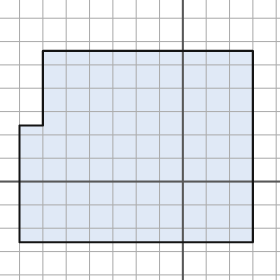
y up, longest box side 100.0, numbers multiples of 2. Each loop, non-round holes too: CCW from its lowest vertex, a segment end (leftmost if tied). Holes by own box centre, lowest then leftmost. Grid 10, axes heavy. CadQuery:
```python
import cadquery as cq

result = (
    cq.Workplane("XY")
    .moveTo(-70.0, -26.0)
    .lineTo(30.0, -26.0)
    .lineTo(30.0, 56.0)
    .lineTo(-60.0, 56.0)
    .lineTo(-60.0, 24.0)
    .lineTo(-70.0, 24.0)
    .close()
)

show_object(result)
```